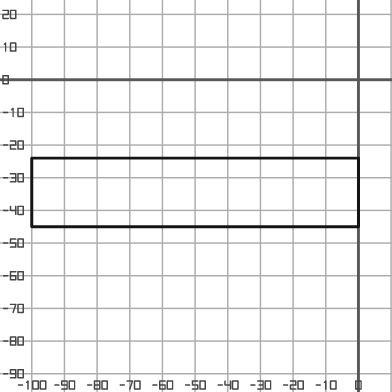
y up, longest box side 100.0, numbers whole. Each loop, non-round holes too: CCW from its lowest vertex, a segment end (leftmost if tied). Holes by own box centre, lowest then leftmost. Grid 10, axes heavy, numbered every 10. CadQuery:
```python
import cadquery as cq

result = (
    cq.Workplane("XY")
    .moveTo(-100.0, -45.0)
    .lineTo(0.0, -45.0)
    .lineTo(0.0, -24.0)
    .lineTo(-100.0, -24.0)
    .close()
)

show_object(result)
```